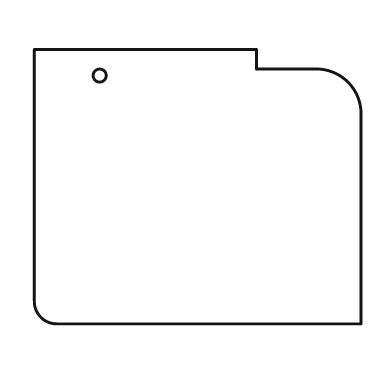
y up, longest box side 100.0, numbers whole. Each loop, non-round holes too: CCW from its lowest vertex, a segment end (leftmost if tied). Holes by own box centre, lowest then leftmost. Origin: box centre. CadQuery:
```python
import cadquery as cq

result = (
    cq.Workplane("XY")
    .moveTo(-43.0, -42.0)
    .lineTo(50.0, -42.0)
    .lineTo(50.0, 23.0)
    .threePointArc((46.0, 32.0), (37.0, 36.0))
    .lineTo(18.0, 36.0)
    .lineTo(18.0, 42.0)
    .lineTo(-50.0, 42.0)
    .lineTo(-50.0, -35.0)
    .threePointArc((-48.0, -40.0), (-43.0, -42.0))
    .close()
    .moveTo(-30.0, 34.0)
    .circle(2.0)
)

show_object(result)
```